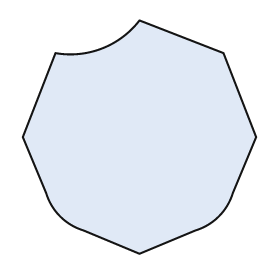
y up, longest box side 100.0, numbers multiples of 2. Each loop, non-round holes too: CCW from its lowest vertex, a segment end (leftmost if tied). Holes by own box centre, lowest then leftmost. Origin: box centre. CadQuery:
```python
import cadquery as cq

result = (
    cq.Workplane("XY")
    .moveTo(0.0, -50.0)
    .lineTo(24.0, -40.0)
    .threePointArc((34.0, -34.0), (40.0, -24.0))
    .lineTo(50.0, 0.0)
    .lineTo(36.0, 36.0)
    .lineTo(0.0, 50.0)
    .threePointArc((-16.0, 38.0), (-36.0, 36.0))
    .lineTo(-50.0, 0.0)
    .lineTo(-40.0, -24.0)
    .threePointArc((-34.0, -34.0), (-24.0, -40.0))
    .close()
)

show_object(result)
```